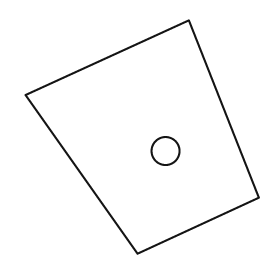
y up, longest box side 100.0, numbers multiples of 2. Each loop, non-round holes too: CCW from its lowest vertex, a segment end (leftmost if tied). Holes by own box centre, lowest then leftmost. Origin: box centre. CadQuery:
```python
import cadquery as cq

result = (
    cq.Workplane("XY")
    .moveTo(-2.0, -50.0)
    .lineTo(50.0, -26.0)
    .lineTo(20.0, 50.0)
    .lineTo(-50.0, 18.0)
    .close()
    .moveTo(10.0, -6.0)
    .circle(6.0)
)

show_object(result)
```